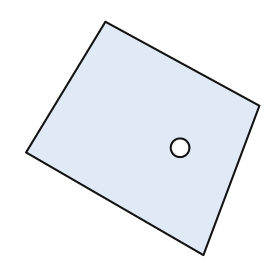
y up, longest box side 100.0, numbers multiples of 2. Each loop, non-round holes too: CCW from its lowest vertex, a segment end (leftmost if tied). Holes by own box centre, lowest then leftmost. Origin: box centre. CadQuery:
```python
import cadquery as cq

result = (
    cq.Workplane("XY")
    .moveTo(26.0, -50.0)
    .lineTo(50.0, 14.0)
    .lineTo(-16.0, 50.0)
    .lineTo(-50.0, -6.0)
    .close()
    .moveTo(16.0, -4.0)
    .circle(4.0)
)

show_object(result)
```